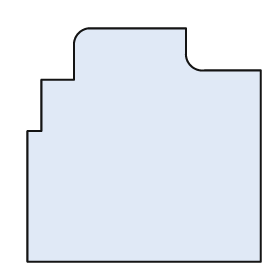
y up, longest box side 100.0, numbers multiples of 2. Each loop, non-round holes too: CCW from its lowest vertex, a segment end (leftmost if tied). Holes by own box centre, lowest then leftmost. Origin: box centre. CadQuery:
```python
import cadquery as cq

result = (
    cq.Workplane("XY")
    .moveTo(-50.0, -50.0)
    .lineTo(50.0, -50.0)
    .lineTo(50.0, 32.0)
    .lineTo(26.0, 32.0)
    .threePointArc((20.0, 34.0), (18.0, 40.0))
    .lineTo(18.0, 50.0)
    .lineTo(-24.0, 50.0)
    .threePointArc((-28.0, 48.0), (-30.0, 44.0))
    .lineTo(-30.0, 28.0)
    .lineTo(-44.0, 28.0)
    .lineTo(-44.0, 6.0)
    .lineTo(-50.0, 6.0)
    .close()
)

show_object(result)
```